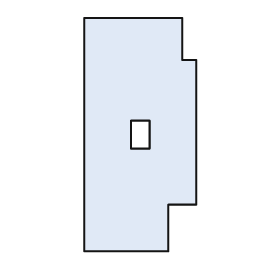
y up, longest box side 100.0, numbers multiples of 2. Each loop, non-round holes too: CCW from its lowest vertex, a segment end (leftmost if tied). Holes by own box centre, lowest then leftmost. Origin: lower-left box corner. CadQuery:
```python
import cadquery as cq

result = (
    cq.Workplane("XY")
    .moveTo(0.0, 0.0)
    .lineTo(36.0, 0.0)
    .lineTo(36.0, 20.0)
    .lineTo(48.0, 20.0)
    .lineTo(48.0, 82.0)
    .lineTo(42.0, 82.0)
    .lineTo(42.0, 100.0)
    .lineTo(0.0, 100.0)
    .close()
    .moveTo(20.0, 44.0)
    .lineTo(28.0, 44.0)
    .lineTo(28.0, 56.0)
    .lineTo(20.0, 56.0)
    .close()
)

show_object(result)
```